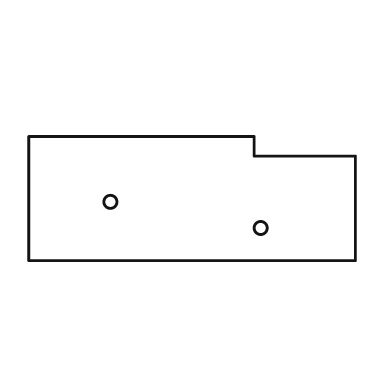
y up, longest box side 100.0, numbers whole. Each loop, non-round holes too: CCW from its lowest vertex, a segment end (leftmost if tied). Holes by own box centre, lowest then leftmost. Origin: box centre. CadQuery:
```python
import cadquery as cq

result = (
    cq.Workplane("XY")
    .moveTo(-50.0, -19.0)
    .lineTo(50.0, -19.0)
    .lineTo(50.0, 13.0)
    .lineTo(19.0, 13.0)
    .lineTo(19.0, 19.0)
    .lineTo(-50.0, 19.0)
    .close()
    .moveTo(21.0, -9.0)
    .circle(2.0)
    .moveTo(-25.0, -1.0)
    .circle(2.0)
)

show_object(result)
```